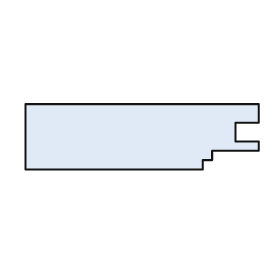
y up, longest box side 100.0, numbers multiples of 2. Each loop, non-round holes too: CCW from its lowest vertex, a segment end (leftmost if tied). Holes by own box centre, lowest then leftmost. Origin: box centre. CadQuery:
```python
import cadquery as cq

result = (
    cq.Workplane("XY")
    .moveTo(-50.0, -14.0)
    .lineTo(26.0, -14.0)
    .lineTo(26.0, -10.0)
    .lineTo(30.0, -10.0)
    .lineTo(30.0, -6.0)
    .lineTo(50.0, -6.0)
    .lineTo(50.0, -2.0)
    .lineTo(40.0, -2.0)
    .lineTo(40.0, 6.0)
    .lineTo(50.0, 6.0)
    .lineTo(50.0, 14.0)
    .lineTo(-50.0, 14.0)
    .close()
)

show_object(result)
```